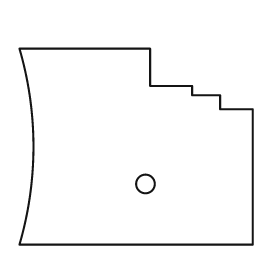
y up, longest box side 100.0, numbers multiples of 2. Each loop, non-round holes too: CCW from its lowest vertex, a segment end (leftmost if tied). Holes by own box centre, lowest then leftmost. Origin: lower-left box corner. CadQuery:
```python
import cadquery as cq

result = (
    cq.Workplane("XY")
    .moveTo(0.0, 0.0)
    .lineTo(100.0, 0.0)
    .lineTo(100.0, 58.0)
    .lineTo(86.0, 58.0)
    .lineTo(86.0, 64.0)
    .lineTo(74.0, 64.0)
    .lineTo(74.0, 68.0)
    .lineTo(56.0, 68.0)
    .lineTo(56.0, 84.0)
    .lineTo(0.0, 84.0)
    .threePointArc((6.0, 42.0), (0.0, 0.0))
    .close()
    .moveTo(54.0, 26.0)
    .circle(4.0)
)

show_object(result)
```